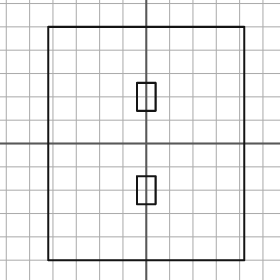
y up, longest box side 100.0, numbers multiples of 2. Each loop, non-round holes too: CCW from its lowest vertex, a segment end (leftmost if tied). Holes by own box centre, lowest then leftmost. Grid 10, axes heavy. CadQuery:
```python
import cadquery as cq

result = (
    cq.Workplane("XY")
    .moveTo(-42.0, -50.0)
    .lineTo(42.0, -50.0)
    .lineTo(42.0, 50.0)
    .lineTo(-42.0, 50.0)
    .close()
    .moveTo(-4.0, -26.0)
    .lineTo(4.0, -26.0)
    .lineTo(4.0, -14.0)
    .lineTo(-4.0, -14.0)
    .close()
    .moveTo(-4.0, 14.0)
    .lineTo(4.0, 14.0)
    .lineTo(4.0, 26.0)
    .lineTo(-4.0, 26.0)
    .close()
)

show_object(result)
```